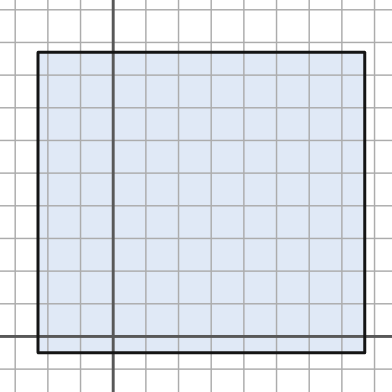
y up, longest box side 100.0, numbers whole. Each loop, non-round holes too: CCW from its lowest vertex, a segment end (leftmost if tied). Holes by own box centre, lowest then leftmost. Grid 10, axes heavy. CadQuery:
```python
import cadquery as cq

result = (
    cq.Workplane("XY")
    .moveTo(-23.0, -5.0)
    .lineTo(77.0, -5.0)
    .lineTo(77.0, 87.0)
    .lineTo(-23.0, 87.0)
    .close()
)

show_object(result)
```